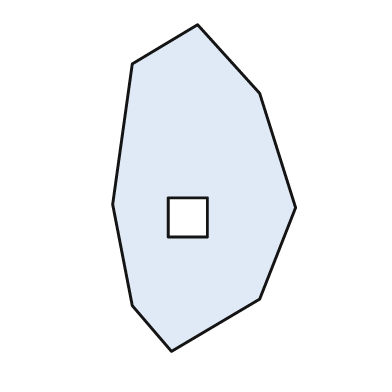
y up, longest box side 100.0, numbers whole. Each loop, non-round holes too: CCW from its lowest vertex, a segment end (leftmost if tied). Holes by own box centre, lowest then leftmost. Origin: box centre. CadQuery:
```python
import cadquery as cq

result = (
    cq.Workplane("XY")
    .moveTo(-10.0, -50.0)
    .lineTo(17.0, -34.0)
    .lineTo(28.0, -6.0)
    .lineTo(17.0, 29.0)
    .lineTo(-2.0, 50.0)
    .lineTo(-22.0, 38.0)
    .lineTo(-28.0, -5.0)
    .lineTo(-22.0, -36.0)
    .close()
    .moveTo(-11.0, -15.0)
    .lineTo(1.0, -15.0)
    .lineTo(1.0, -3.0)
    .lineTo(-11.0, -3.0)
    .close()
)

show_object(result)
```